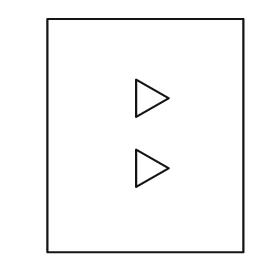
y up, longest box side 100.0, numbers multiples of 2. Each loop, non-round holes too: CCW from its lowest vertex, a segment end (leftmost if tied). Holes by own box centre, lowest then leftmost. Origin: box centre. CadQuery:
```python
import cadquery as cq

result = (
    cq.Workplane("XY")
    .moveTo(-42.0, -50.0)
    .lineTo(42.0, -50.0)
    .lineTo(42.0, 50.0)
    .lineTo(-42.0, 50.0)
    .close()
    .moveTo(-4.0, -22.0)
    .lineTo(10.0, -14.0)
    .lineTo(-4.0, -6.0)
    .close()
    .moveTo(-4.0, 8.0)
    .lineTo(10.0, 16.0)
    .lineTo(-4.0, 24.0)
    .close()
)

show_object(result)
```